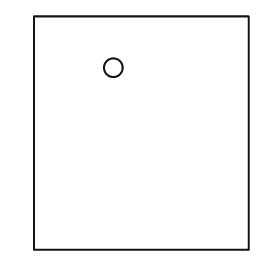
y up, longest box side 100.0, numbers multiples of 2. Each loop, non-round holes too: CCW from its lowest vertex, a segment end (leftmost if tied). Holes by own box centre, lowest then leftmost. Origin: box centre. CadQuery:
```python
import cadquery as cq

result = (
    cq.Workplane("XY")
    .moveTo(-46.0, -50.0)
    .lineTo(46.0, -50.0)
    .lineTo(46.0, 50.0)
    .lineTo(-46.0, 50.0)
    .close()
    .moveTo(-12.0, 28.0)
    .circle(4.0)
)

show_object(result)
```